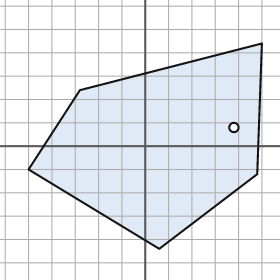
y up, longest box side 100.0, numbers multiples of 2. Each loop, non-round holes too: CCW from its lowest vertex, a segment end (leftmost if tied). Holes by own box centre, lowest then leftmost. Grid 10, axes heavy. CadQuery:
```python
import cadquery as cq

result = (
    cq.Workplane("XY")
    .moveTo(6.0, -44.0)
    .lineTo(48.0, -12.0)
    .lineTo(50.0, 44.0)
    .lineTo(-28.0, 24.0)
    .lineTo(-50.0, -10.0)
    .close()
    .moveTo(38.0, 8.0)
    .circle(2.0)
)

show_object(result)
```